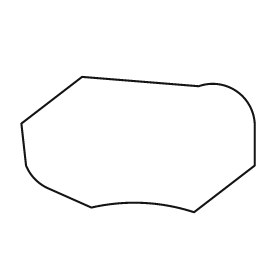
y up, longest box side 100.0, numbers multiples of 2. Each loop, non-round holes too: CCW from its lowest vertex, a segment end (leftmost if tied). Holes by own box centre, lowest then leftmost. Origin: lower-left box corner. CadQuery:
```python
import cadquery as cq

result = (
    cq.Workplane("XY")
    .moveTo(74.0, 0.0)
    .lineTo(100.0, 20.0)
    .lineTo(100.0, 38.0)
    .threePointArc((92.0, 52.0), (76.0, 54.0))
    .lineTo(26.0, 58.0)
    .lineTo(0.0, 38.0)
    .lineTo(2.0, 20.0)
    .threePointArc((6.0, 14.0), (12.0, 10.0))
    .lineTo(30.0, 2.0)
    .threePointArc((52.0, 4.0), (74.0, 0.0))
    .close()
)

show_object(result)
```